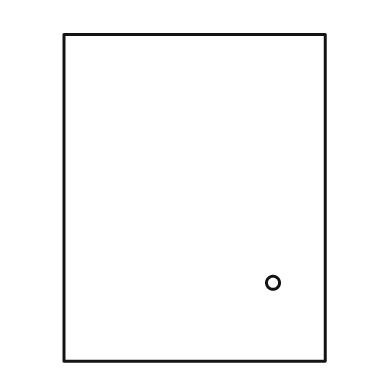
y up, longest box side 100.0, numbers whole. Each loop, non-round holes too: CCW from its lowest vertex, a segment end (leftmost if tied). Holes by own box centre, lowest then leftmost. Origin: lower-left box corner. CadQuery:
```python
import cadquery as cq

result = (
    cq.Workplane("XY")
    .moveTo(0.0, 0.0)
    .lineTo(80.0, 0.0)
    .lineTo(80.0, 100.0)
    .lineTo(0.0, 100.0)
    .close()
    .moveTo(64.0, 24.0)
    .circle(2.0)
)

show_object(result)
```